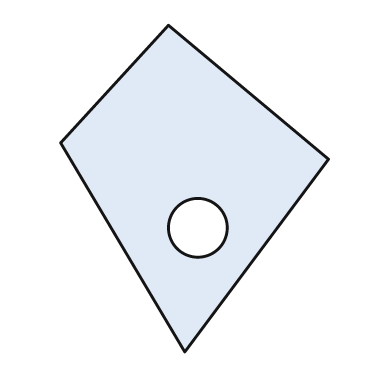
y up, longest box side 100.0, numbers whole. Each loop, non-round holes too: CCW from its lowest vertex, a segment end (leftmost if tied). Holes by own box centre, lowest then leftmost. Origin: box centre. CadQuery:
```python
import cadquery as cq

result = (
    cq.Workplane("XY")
    .moveTo(-3.0, -50.0)
    .lineTo(41.0, 9.0)
    .lineTo(-8.0, 50.0)
    .lineTo(-41.0, 14.0)
    .close()
    .moveTo(1.0, -12.0)
    .circle(9.0)
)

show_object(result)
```